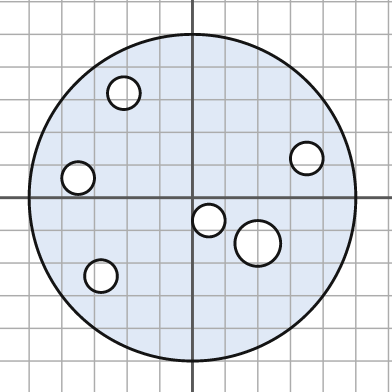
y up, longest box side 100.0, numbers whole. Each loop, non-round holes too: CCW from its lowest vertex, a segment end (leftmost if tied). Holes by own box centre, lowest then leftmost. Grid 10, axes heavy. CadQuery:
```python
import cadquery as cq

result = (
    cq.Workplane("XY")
    .moveTo(0.0, 0.0)
    .circle(50.0)
    .moveTo(-28.0, -24.0)
    .circle(5.0)
    .moveTo(20.0, -14.0)
    .circle(7.0)
    .moveTo(5.0, -7.0)
    .circle(5.0)
    .moveTo(-35.0, 6.0)
    .circle(5.0)
    .moveTo(35.0, 12.0)
    .circle(5.0)
    .moveTo(-21.0, 32.0)
    .circle(5.0)
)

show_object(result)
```